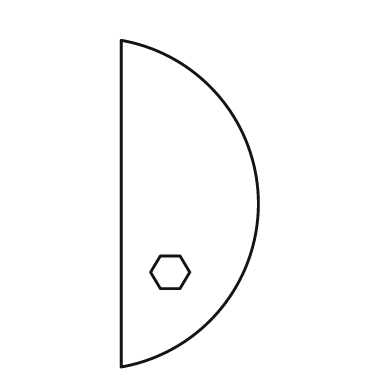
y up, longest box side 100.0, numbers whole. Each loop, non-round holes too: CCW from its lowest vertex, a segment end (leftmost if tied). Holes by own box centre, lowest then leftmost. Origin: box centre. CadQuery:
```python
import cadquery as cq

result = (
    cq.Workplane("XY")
    .moveTo(-21.0, -50.0)
    .threePointArc((21.0, 0.0), (-21.0, 50.0))
    .close()
    .moveTo(-9.0, -26.0)
    .lineTo(-3.0, -26.0)
    .lineTo(0.0, -21.0)
    .lineTo(-3.0, -16.0)
    .lineTo(-9.0, -16.0)
    .lineTo(-12.0, -21.0)
    .close()
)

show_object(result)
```